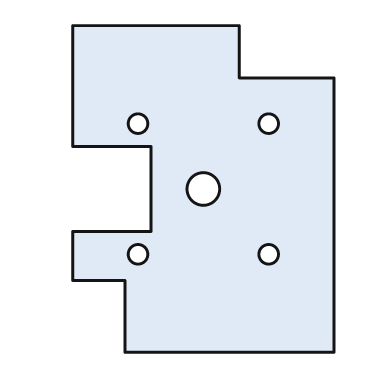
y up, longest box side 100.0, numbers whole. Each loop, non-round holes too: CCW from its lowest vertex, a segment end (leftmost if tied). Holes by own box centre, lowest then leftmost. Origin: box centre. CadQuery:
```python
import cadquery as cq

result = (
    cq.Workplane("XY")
    .moveTo(-24.0, -50.0)
    .lineTo(40.0, -50.0)
    .lineTo(40.0, 34.0)
    .lineTo(11.0, 34.0)
    .lineTo(11.0, 50.0)
    .lineTo(-40.0, 50.0)
    .lineTo(-40.0, 13.0)
    .lineTo(-16.0, 13.0)
    .lineTo(-16.0, -13.0)
    .lineTo(-40.0, -13.0)
    .lineTo(-40.0, -28.0)
    .lineTo(-24.0, -28.0)
    .close()
    .moveTo(-20.0, -20.0)
    .circle(3.0)
    .moveTo(20.0, -20.0)
    .circle(3.0)
    .moveTo(0.0, 0.0)
    .circle(5.0)
    .moveTo(-20.0, 20.0)
    .circle(3.0)
    .moveTo(20.0, 20.0)
    .circle(3.0)
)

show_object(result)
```